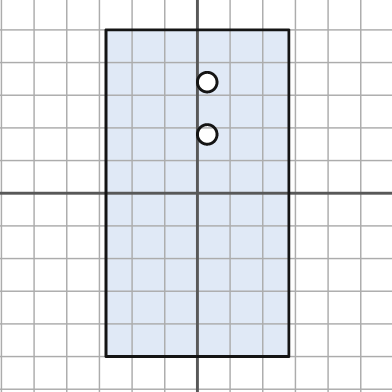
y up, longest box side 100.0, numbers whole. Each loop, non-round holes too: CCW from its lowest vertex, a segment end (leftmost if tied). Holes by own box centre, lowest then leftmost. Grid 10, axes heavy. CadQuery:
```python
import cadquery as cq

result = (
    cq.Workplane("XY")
    .moveTo(-28.0, -50.0)
    .lineTo(28.0, -50.0)
    .lineTo(28.0, 50.0)
    .lineTo(-28.0, 50.0)
    .close()
    .moveTo(3.0, 18.0)
    .circle(3.0)
    .moveTo(3.0, 34.0)
    .circle(3.0)
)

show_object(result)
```